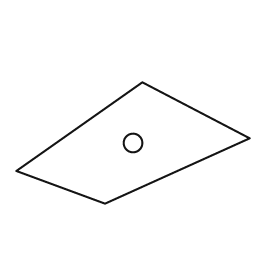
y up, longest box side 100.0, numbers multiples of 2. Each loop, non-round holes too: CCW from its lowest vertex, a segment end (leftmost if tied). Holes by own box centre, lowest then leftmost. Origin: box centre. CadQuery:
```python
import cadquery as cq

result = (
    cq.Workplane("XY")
    .moveTo(-12.0, -26.0)
    .lineTo(50.0, 2.0)
    .lineTo(4.0, 26.0)
    .lineTo(-50.0, -12.0)
    .close()
    .moveTo(0.0, 0.0)
    .circle(4.0)
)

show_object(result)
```